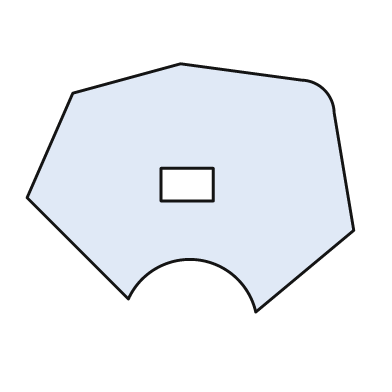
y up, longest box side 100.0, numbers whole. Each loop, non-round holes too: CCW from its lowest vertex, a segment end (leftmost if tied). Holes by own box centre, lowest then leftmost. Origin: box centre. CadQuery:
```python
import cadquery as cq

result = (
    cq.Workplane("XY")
    .moveTo(20.0, -38.0)
    .lineTo(50.0, -13.0)
    .lineTo(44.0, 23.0)
    .threePointArc((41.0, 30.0), (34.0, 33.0))
    .lineTo(-3.0, 38.0)
    .lineTo(-36.0, 29.0)
    .lineTo(-50.0, -3.0)
    .lineTo(-19.0, -34.0)
    .threePointArc((2.0, -22.0), (20.0, -38.0))
    .close()
    .moveTo(-9.0, -4.0)
    .lineTo(7.0, -4.0)
    .lineTo(7.0, 6.0)
    .lineTo(-9.0, 6.0)
    .close()
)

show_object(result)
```